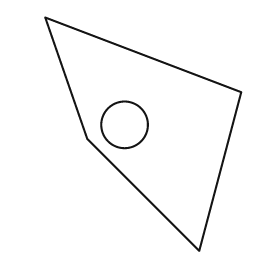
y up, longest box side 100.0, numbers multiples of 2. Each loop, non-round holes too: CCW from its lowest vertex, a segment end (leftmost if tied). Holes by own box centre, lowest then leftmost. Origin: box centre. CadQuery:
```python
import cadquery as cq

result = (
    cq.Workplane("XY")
    .moveTo(24.0, -50.0)
    .lineTo(42.0, 18.0)
    .lineTo(-42.0, 50.0)
    .lineTo(-24.0, -2.0)
    .close()
    .moveTo(-8.0, 4.0)
    .circle(10.0)
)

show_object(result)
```